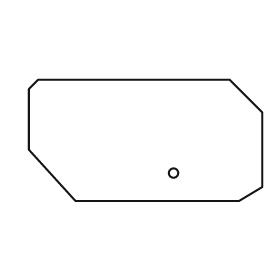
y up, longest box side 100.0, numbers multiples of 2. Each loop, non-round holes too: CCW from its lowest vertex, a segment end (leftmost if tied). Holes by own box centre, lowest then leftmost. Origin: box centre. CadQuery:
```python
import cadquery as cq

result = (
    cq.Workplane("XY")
    .moveTo(-30.0, -26.0)
    .lineTo(40.0, -26.0)
    .lineTo(50.0, -20.0)
    .lineTo(50.0, 12.0)
    .lineTo(36.0, 26.0)
    .lineTo(-46.0, 26.0)
    .lineTo(-50.0, 22.0)
    .lineTo(-50.0, -4.0)
    .close()
    .moveTo(12.0, -14.0)
    .circle(2.0)
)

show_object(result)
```